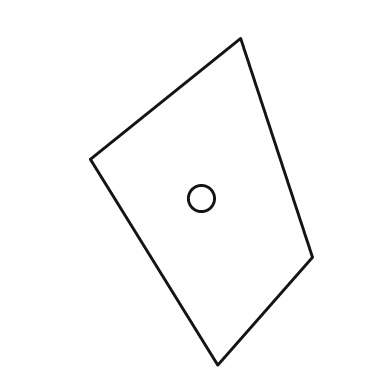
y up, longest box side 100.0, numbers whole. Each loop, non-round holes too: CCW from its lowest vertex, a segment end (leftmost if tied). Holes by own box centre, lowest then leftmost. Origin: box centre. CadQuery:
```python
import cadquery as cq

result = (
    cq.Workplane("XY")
    .moveTo(5.0, -50.0)
    .lineTo(34.0, -17.0)
    .lineTo(12.0, 50.0)
    .lineTo(-34.0, 13.0)
    .close()
    .moveTo(0.0, 1.0)
    .circle(4.0)
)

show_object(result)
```